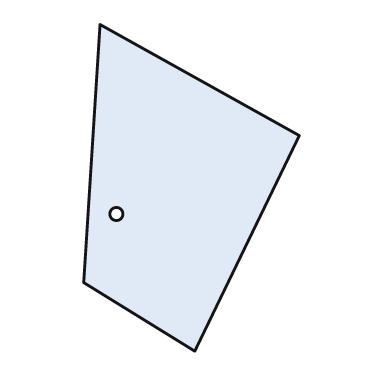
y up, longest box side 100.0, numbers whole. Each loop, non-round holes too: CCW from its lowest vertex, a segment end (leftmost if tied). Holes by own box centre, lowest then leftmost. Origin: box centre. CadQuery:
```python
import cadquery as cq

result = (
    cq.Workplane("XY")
    .moveTo(1.0, -50.0)
    .lineTo(33.0, 16.0)
    .lineTo(-28.0, 50.0)
    .lineTo(-33.0, -29.0)
    .close()
    .moveTo(-23.0, -8.0)
    .circle(2.0)
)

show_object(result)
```